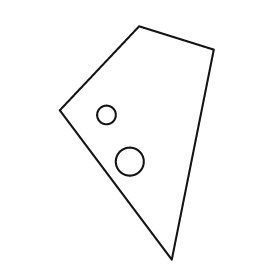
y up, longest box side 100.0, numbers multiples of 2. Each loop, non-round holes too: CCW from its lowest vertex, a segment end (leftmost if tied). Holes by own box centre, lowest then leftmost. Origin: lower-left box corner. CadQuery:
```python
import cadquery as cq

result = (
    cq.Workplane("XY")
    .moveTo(48.0, 0.0)
    .lineTo(66.0, 90.0)
    .lineTo(34.0, 100.0)
    .lineTo(0.0, 64.0)
    .close()
    .moveTo(30.0, 42.0)
    .circle(6.0)
    .moveTo(20.0, 62.0)
    .circle(4.0)
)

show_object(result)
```